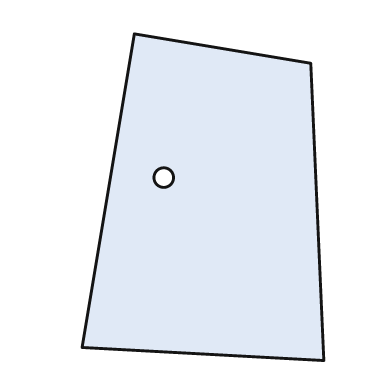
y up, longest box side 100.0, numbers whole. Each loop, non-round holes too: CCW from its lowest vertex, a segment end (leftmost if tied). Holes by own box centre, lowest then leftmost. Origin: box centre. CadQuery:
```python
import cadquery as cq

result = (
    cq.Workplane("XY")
    .moveTo(37.0, -50.0)
    .lineTo(33.0, 41.0)
    .lineTo(-21.0, 50.0)
    .lineTo(-37.0, -46.0)
    .close()
    .moveTo(-12.0, 6.0)
    .circle(3.0)
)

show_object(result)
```